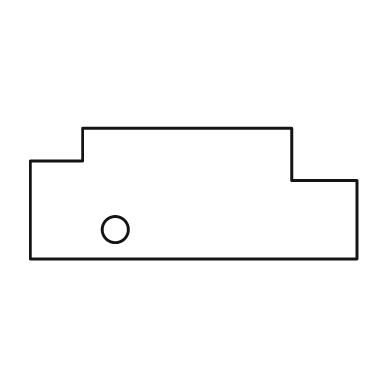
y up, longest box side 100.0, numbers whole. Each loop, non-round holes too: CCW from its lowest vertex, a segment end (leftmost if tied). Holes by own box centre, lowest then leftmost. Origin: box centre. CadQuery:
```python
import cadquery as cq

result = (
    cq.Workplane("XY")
    .moveTo(-50.0, -20.0)
    .lineTo(50.0, -20.0)
    .lineTo(50.0, 4.0)
    .lineTo(30.0, 4.0)
    .lineTo(30.0, 20.0)
    .lineTo(-34.0, 20.0)
    .lineTo(-34.0, 10.0)
    .lineTo(-50.0, 10.0)
    .close()
    .moveTo(-24.0, -11.0)
    .circle(4.0)
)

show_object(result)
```